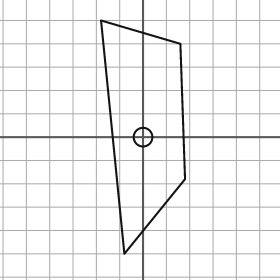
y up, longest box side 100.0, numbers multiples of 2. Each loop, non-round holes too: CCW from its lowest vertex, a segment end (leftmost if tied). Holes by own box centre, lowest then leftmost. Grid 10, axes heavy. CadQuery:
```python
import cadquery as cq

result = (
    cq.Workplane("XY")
    .moveTo(-8.0, -50.0)
    .lineTo(18.0, -18.0)
    .lineTo(16.0, 40.0)
    .lineTo(-18.0, 50.0)
    .close()
    .moveTo(0.0, 0.0)
    .circle(4.0)
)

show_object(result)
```